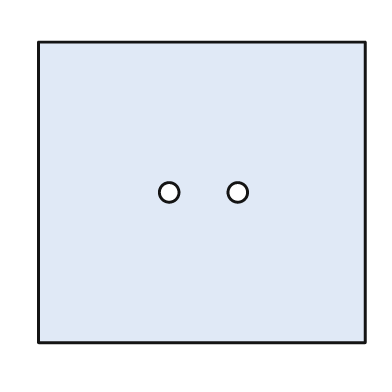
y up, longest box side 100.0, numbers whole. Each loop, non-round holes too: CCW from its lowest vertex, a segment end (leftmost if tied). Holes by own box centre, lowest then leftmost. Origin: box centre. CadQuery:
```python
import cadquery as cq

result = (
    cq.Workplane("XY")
    .moveTo(-50.0, -46.0)
    .lineTo(50.0, -46.0)
    .lineTo(50.0, 46.0)
    .lineTo(-50.0, 46.0)
    .close()
    .moveTo(-10.0, 0.0)
    .circle(3.0)
    .moveTo(11.0, 0.0)
    .circle(3.0)
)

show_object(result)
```